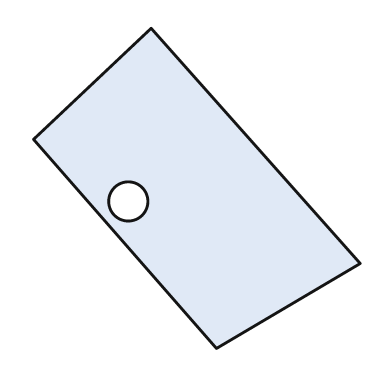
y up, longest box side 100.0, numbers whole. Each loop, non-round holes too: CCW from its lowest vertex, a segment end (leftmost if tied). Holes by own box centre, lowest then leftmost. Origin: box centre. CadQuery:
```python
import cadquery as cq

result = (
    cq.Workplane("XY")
    .moveTo(6.0, -49.0)
    .lineTo(50.0, -23.0)
    .lineTo(-14.0, 49.0)
    .lineTo(-50.0, 15.0)
    .close()
    .moveTo(-21.0, -4.0)
    .circle(6.0)
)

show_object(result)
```